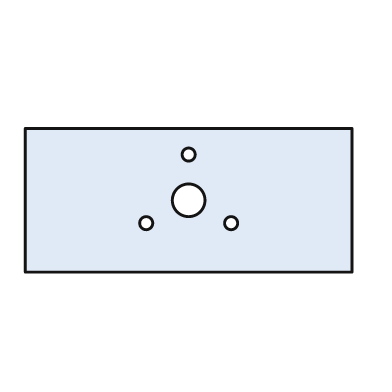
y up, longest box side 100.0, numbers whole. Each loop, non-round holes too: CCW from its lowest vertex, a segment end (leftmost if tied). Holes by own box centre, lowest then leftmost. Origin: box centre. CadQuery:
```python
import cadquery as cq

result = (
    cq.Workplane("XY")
    .moveTo(-50.0, -22.0)
    .lineTo(50.0, -22.0)
    .lineTo(50.0, 22.0)
    .lineTo(-50.0, 22.0)
    .close()
    .moveTo(-13.0, -7.0)
    .circle(2.0)
    .moveTo(13.0, -7.0)
    .circle(2.0)
    .moveTo(0.0, 0.0)
    .circle(5.0)
    .moveTo(0.0, 14.0)
    .circle(2.0)
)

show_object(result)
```